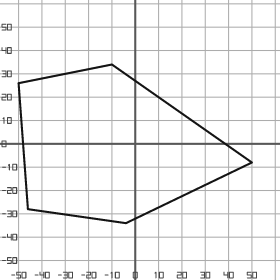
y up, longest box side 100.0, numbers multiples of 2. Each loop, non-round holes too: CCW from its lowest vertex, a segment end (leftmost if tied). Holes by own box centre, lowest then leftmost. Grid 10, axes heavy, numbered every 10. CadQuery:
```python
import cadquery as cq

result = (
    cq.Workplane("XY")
    .moveTo(-4.0, -34.0)
    .lineTo(50.0, -8.0)
    .lineTo(-10.0, 34.0)
    .lineTo(-50.0, 26.0)
    .lineTo(-46.0, -28.0)
    .close()
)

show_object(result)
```